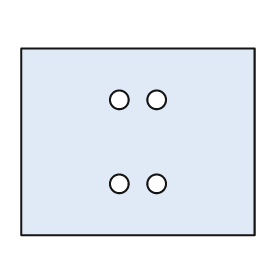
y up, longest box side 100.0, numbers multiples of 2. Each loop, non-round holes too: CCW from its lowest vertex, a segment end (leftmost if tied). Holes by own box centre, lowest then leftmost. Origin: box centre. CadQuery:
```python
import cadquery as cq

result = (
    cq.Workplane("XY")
    .moveTo(-50.0, -40.0)
    .lineTo(50.0, -40.0)
    .lineTo(50.0, 40.0)
    .lineTo(-50.0, 40.0)
    .close()
    .moveTo(-8.0, -18.0)
    .circle(4.0)
    .moveTo(8.0, -18.0)
    .circle(4.0)
    .moveTo(-8.0, 18.0)
    .circle(4.0)
    .moveTo(8.0, 18.0)
    .circle(4.0)
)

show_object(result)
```